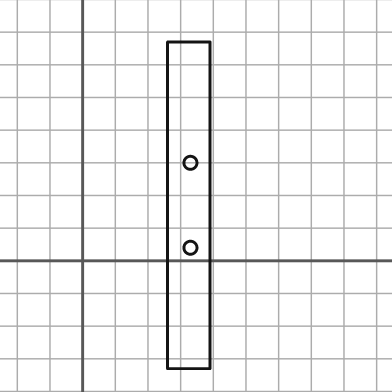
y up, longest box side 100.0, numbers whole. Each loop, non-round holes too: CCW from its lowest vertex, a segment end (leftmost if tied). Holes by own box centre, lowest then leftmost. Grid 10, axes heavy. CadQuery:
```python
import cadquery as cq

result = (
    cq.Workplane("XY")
    .moveTo(26.0, -33.0)
    .lineTo(39.0, -33.0)
    .lineTo(39.0, 67.0)
    .lineTo(26.0, 67.0)
    .close()
    .moveTo(33.0, 4.0)
    .circle(2.0)
    .moveTo(33.0, 30.0)
    .circle(2.0)
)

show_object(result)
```